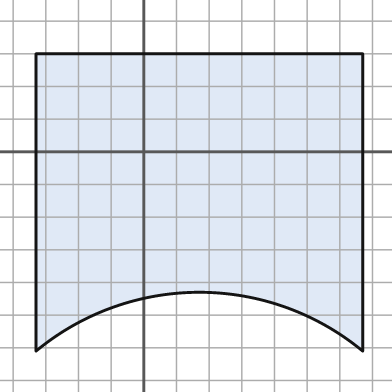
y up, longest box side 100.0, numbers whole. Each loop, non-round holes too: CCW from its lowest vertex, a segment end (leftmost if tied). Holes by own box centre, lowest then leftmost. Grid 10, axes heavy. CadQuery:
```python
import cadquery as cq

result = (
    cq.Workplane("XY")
    .moveTo(-33.0, -61.0)
    .threePointArc((17.0, -43.0), (67.0, -61.0))
    .lineTo(67.0, 30.0)
    .lineTo(-33.0, 30.0)
    .close()
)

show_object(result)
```